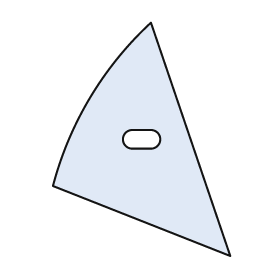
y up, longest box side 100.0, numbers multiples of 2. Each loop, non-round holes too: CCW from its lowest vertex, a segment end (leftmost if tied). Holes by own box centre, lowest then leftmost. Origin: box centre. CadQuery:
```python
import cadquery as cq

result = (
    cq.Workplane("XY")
    .moveTo(38.0, -50.0)
    .lineTo(4.0, 50.0)
    .threePointArc((-22.0, 18.0), (-38.0, -20.0))
    .close()
    .moveTo(-4.0, -4.0)
    .lineTo(4.0, -4.0)
    .threePointArc((8.0, 0.0), (4.0, 4.0))
    .lineTo(-4.0, 4.0)
    .threePointArc((-8.0, 0.0), (-4.0, -4.0))
    .close()
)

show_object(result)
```